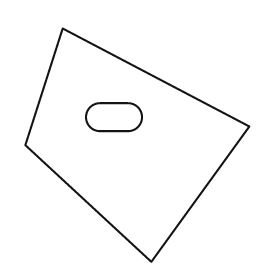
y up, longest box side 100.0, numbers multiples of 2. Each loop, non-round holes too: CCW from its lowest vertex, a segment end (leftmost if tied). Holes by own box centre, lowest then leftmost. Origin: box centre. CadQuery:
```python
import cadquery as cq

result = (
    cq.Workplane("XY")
    .moveTo(6.0, -50.0)
    .lineTo(48.0, 8.0)
    .lineTo(-32.0, 50.0)
    .lineTo(-48.0, 0.0)
    .close()
    .moveTo(-16.0, 6.0)
    .lineTo(-4.0, 6.0)
    .threePointArc((2.0, 12.0), (-4.0, 18.0))
    .lineTo(-16.0, 18.0)
    .threePointArc((-22.0, 12.0), (-16.0, 6.0))
    .close()
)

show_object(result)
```